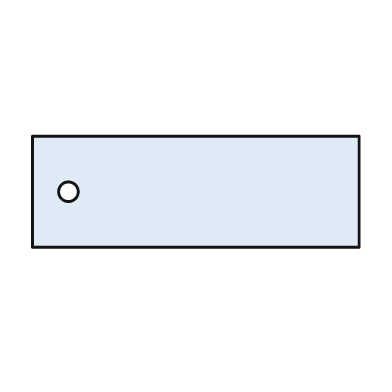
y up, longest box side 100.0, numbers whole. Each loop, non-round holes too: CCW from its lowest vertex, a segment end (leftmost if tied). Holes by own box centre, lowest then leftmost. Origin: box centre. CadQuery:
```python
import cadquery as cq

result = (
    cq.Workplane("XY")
    .moveTo(-50.0, -17.0)
    .lineTo(50.0, -17.0)
    .lineTo(50.0, 17.0)
    .lineTo(-50.0, 17.0)
    .close()
    .moveTo(-39.0, 0.0)
    .circle(3.0)
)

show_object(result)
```